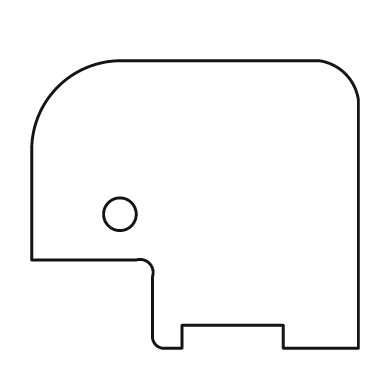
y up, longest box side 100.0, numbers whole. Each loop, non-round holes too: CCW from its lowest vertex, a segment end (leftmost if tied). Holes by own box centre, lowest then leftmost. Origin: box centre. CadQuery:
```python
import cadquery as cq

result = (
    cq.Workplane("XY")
    .moveTo(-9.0, -44.0)
    .lineTo(-4.0, -44.0)
    .lineTo(-4.0, -37.0)
    .lineTo(27.0, -37.0)
    .lineTo(27.0, -44.0)
    .lineTo(50.0, -44.0)
    .lineTo(50.0, 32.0)
    .threePointArc((46.0, 40.0), (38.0, 44.0))
    .lineTo(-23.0, 44.0)
    .threePointArc((-42.0, 36.0), (-50.0, 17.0))
    .lineTo(-50.0, -17.0)
    .lineTo(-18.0, -17.0)
    .threePointArc((-14.0, -18.0), (-13.0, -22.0))
    .lineTo(-13.0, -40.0)
    .threePointArc((-12.0, -43.0), (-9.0, -44.0))
    .close()
    .moveTo(-23.0, -3.0)
    .circle(5.0)
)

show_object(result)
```